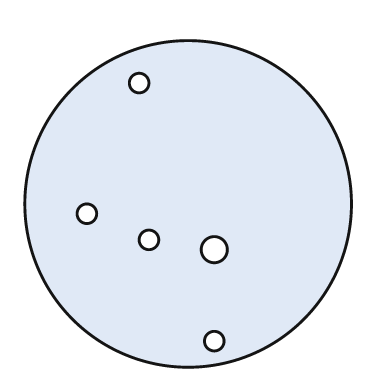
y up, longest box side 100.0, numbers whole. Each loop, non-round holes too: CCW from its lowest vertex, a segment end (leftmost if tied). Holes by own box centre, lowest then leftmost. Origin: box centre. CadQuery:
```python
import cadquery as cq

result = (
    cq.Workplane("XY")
    .moveTo(0.0, 0.0)
    .circle(50.0)
    .moveTo(8.0, -42.0)
    .circle(3.0)
    .moveTo(8.0, -14.0)
    .circle(4.0)
    .moveTo(-12.0, -11.0)
    .circle(3.0)
    .moveTo(-31.0, -3.0)
    .circle(3.0)
    .moveTo(-15.0, 37.0)
    .circle(3.0)
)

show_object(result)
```